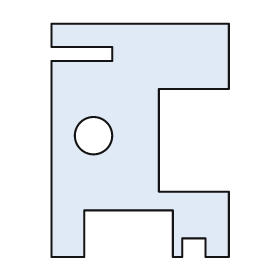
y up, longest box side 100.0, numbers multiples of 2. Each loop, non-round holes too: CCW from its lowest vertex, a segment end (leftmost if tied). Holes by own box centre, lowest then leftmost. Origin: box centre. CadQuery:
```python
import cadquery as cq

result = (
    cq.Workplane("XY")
    .moveTo(-38.0, -50.0)
    .lineTo(-24.0, -50.0)
    .lineTo(-24.0, -30.0)
    .lineTo(14.0, -30.0)
    .lineTo(14.0, -50.0)
    .lineTo(18.0, -50.0)
    .lineTo(18.0, -42.0)
    .lineTo(28.0, -42.0)
    .lineTo(28.0, -50.0)
    .lineTo(38.0, -50.0)
    .lineTo(38.0, -22.0)
    .lineTo(8.0, -22.0)
    .lineTo(8.0, 22.0)
    .lineTo(38.0, 22.0)
    .lineTo(38.0, 50.0)
    .lineTo(-38.0, 50.0)
    .lineTo(-38.0, 40.0)
    .lineTo(-12.0, 40.0)
    .lineTo(-12.0, 34.0)
    .lineTo(-38.0, 34.0)
    .close()
    .moveTo(-20.0, 2.0)
    .circle(8.0)
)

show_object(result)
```